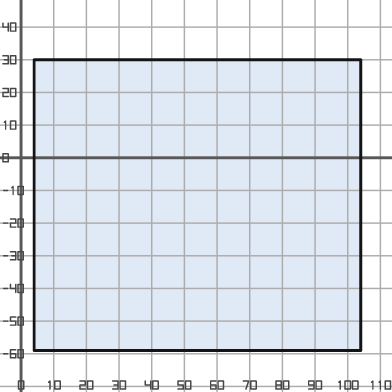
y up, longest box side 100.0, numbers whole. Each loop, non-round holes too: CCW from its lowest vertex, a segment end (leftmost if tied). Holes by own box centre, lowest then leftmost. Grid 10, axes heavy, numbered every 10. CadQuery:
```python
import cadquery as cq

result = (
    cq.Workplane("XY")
    .moveTo(4.0, -59.0)
    .lineTo(104.0, -59.0)
    .lineTo(104.0, 30.0)
    .lineTo(4.0, 30.0)
    .close()
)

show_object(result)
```